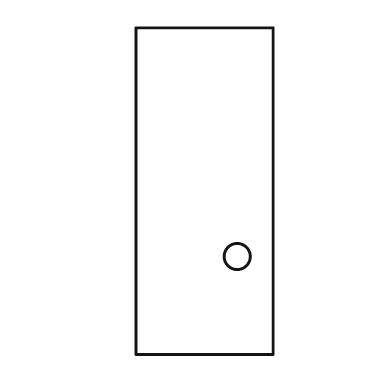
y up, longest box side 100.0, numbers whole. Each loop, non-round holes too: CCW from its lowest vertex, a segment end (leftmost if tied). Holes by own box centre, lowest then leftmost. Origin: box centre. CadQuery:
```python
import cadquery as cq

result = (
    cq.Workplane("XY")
    .moveTo(-21.0, -50.0)
    .lineTo(21.0, -50.0)
    .lineTo(21.0, 50.0)
    .lineTo(-21.0, 50.0)
    .close()
    .moveTo(10.0, -20.0)
    .circle(4.0)
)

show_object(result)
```